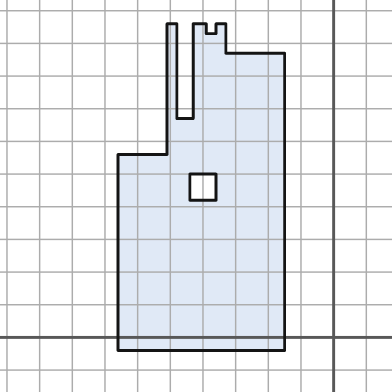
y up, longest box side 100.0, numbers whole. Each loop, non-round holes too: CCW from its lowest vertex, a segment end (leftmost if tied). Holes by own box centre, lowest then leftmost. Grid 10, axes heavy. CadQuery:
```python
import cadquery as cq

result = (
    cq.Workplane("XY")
    .moveTo(-66.0, -4.0)
    .lineTo(-15.0, -4.0)
    .lineTo(-15.0, 87.0)
    .lineTo(-33.0, 87.0)
    .lineTo(-33.0, 96.0)
    .lineTo(-36.0, 96.0)
    .lineTo(-36.0, 93.0)
    .lineTo(-39.0, 93.0)
    .lineTo(-39.0, 96.0)
    .lineTo(-43.0, 96.0)
    .lineTo(-43.0, 67.0)
    .lineTo(-48.0, 67.0)
    .lineTo(-48.0, 96.0)
    .lineTo(-51.0, 96.0)
    .lineTo(-51.0, 56.0)
    .lineTo(-66.0, 56.0)
    .close()
    .moveTo(-44.0, 42.0)
    .lineTo(-36.0, 42.0)
    .lineTo(-36.0, 50.0)
    .lineTo(-44.0, 50.0)
    .close()
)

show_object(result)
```